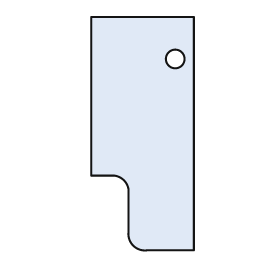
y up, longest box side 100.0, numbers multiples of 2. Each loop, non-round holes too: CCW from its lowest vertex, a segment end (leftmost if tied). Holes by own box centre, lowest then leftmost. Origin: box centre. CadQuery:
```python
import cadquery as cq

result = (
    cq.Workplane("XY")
    .moveTo(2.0, -50.0)
    .lineTo(22.0, -50.0)
    .lineTo(22.0, 50.0)
    .lineTo(-22.0, 50.0)
    .lineTo(-22.0, -18.0)
    .lineTo(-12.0, -18.0)
    .threePointArc((-8.0, -20.0), (-6.0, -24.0))
    .lineTo(-6.0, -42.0)
    .threePointArc((-4.0, -48.0), (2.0, -50.0))
    .close()
    .moveTo(14.0, 32.0)
    .circle(4.0)
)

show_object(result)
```